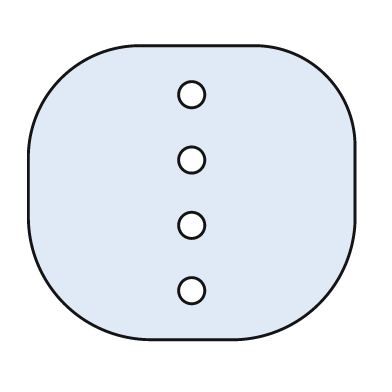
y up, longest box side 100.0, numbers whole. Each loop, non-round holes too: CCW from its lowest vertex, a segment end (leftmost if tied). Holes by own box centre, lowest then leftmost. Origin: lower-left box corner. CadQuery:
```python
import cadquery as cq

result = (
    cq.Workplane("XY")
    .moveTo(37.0, 0.0)
    .lineTo(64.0, 0.0)
    .threePointArc((89.0, 11.0), (100.0, 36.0))
    .lineTo(100.0, 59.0)
    .threePointArc((91.0, 81.0), (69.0, 90.0))
    .lineTo(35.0, 90.0)
    .threePointArc((10.0, 80.0), (0.0, 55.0))
    .lineTo(0.0, 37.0)
    .threePointArc((11.0, 11.0), (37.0, 0.0))
    .close()
    .moveTo(50.0, 15.0)
    .circle(4.0)
    .moveTo(50.0, 35.0)
    .circle(4.0)
    .moveTo(50.0, 55.0)
    .circle(4.0)
    .moveTo(50.0, 75.0)
    .circle(4.0)
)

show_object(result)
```